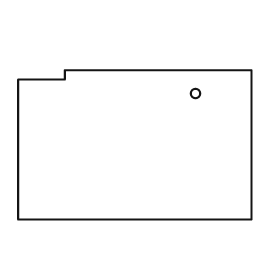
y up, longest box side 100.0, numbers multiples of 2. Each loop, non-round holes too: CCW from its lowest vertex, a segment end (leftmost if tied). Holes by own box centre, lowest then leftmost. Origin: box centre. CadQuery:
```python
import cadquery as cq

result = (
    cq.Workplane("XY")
    .moveTo(-50.0, -32.0)
    .lineTo(50.0, -32.0)
    .lineTo(50.0, 32.0)
    .lineTo(-30.0, 32.0)
    .lineTo(-30.0, 28.0)
    .lineTo(-50.0, 28.0)
    .close()
    .moveTo(26.0, 22.0)
    .circle(2.0)
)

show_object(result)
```